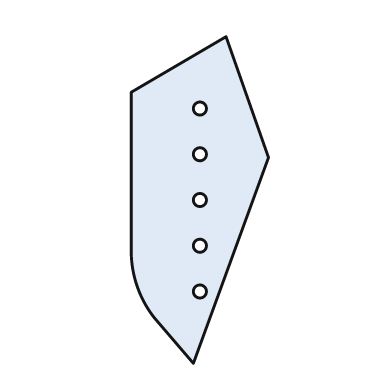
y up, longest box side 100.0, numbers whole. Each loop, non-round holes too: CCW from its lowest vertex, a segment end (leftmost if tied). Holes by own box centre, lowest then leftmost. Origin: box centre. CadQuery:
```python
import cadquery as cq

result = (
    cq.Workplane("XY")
    .moveTo(-2.0, -50.0)
    .lineTo(21.0, 13.0)
    .lineTo(8.0, 50.0)
    .lineTo(-21.0, 33.0)
    .lineTo(-21.0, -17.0)
    .threePointArc((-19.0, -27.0), (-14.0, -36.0))
    .close()
    .moveTo(0.0, -28.0)
    .circle(2.0)
    .moveTo(0.0, -14.0)
    .circle(2.0)
    .moveTo(0.0, 0.0)
    .circle(2.0)
    .moveTo(0.0, 14.0)
    .circle(2.0)
    .moveTo(0.0, 28.0)
    .circle(2.0)
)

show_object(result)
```